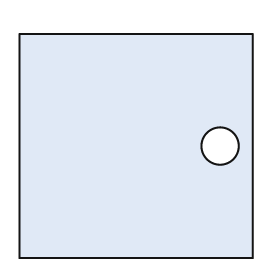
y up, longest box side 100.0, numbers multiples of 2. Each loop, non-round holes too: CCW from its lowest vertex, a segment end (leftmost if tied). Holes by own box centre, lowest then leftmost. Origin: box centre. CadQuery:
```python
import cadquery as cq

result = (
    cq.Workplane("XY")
    .moveTo(-50.0, -48.0)
    .lineTo(50.0, -48.0)
    .lineTo(50.0, 48.0)
    .lineTo(-50.0, 48.0)
    .close()
    .moveTo(36.0, 0.0)
    .circle(8.0)
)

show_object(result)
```